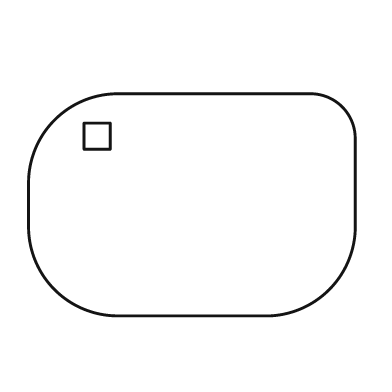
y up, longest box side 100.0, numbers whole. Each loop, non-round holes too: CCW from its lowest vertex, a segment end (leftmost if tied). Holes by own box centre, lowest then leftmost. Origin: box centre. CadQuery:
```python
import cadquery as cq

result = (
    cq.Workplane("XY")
    .moveTo(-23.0, -34.0)
    .lineTo(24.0, -34.0)
    .threePointArc((42.0, -26.0), (50.0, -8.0))
    .lineTo(50.0, 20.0)
    .threePointArc((46.0, 30.0), (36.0, 34.0))
    .lineTo(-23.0, 34.0)
    .threePointArc((-42.0, 26.0), (-50.0, 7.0))
    .lineTo(-50.0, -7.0)
    .threePointArc((-42.0, -26.0), (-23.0, -34.0))
    .close()
    .moveTo(-33.0, 17.0)
    .lineTo(-25.0, 17.0)
    .lineTo(-25.0, 25.0)
    .lineTo(-33.0, 25.0)
    .close()
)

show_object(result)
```